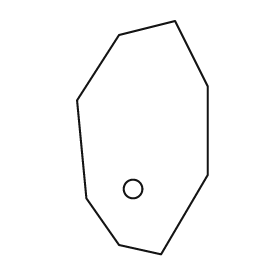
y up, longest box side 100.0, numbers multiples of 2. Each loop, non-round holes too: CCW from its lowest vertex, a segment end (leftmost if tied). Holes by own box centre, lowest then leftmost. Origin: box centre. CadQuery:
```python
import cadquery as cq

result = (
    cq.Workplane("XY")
    .moveTo(8.0, -50.0)
    .lineTo(28.0, -16.0)
    .lineTo(28.0, 22.0)
    .lineTo(14.0, 50.0)
    .lineTo(-10.0, 44.0)
    .lineTo(-28.0, 16.0)
    .lineTo(-24.0, -26.0)
    .lineTo(-10.0, -46.0)
    .close()
    .moveTo(-4.0, -22.0)
    .circle(4.0)
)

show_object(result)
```